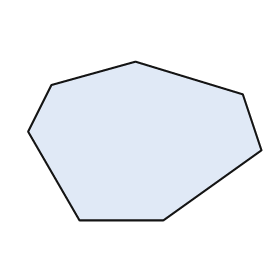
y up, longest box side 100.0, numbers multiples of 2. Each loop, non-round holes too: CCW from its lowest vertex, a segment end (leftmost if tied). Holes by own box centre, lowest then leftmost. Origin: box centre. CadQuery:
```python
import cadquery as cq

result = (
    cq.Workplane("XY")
    .moveTo(-28.0, -34.0)
    .lineTo(8.0, -34.0)
    .lineTo(50.0, -4.0)
    .lineTo(42.0, 20.0)
    .lineTo(-4.0, 34.0)
    .lineTo(-40.0, 24.0)
    .lineTo(-50.0, 4.0)
    .close()
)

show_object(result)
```